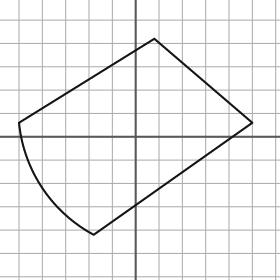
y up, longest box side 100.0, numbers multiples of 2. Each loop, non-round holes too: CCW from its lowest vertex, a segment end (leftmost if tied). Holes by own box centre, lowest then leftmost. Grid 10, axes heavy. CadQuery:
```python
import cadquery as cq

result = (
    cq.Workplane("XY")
    .moveTo(-18.0, -42.0)
    .lineTo(50.0, 6.0)
    .lineTo(8.0, 42.0)
    .lineTo(-50.0, 6.0)
    .threePointArc((-40.0, -22.0), (-18.0, -42.0))
    .close()
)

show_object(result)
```